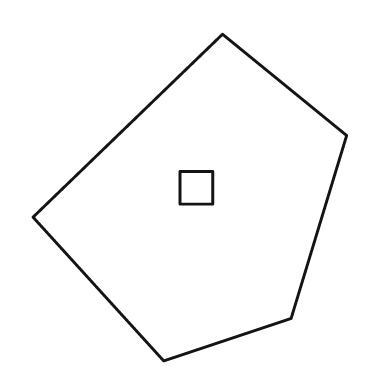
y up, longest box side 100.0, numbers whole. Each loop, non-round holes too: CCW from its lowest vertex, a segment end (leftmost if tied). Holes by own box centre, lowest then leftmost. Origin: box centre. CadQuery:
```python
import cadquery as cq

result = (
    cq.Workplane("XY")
    .moveTo(-8.0, -50.0)
    .lineTo(31.0, -37.0)
    .lineTo(48.0, 19.0)
    .lineTo(10.0, 50.0)
    .lineTo(-48.0, -6.0)
    .close()
    .moveTo(-3.0, -2.0)
    .lineTo(7.0, -2.0)
    .lineTo(7.0, 8.0)
    .lineTo(-3.0, 8.0)
    .close()
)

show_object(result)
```